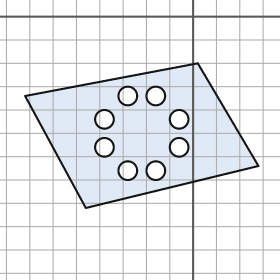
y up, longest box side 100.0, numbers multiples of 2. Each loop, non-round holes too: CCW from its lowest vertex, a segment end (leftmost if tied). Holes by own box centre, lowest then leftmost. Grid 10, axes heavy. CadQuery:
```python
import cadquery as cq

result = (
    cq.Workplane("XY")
    .moveTo(-46.0, -82.0)
    .lineTo(28.0, -64.0)
    .lineTo(2.0, -20.0)
    .lineTo(-72.0, -34.0)
    .close()
    .moveTo(-28.0, -66.0)
    .circle(4.0)
    .moveTo(-16.0, -66.0)
    .circle(4.0)
    .moveTo(-38.0, -56.0)
    .circle(4.0)
    .moveTo(-6.0, -56.0)
    .circle(4.0)
    .moveTo(-38.0, -44.0)
    .circle(4.0)
    .moveTo(-6.0, -44.0)
    .circle(4.0)
    .moveTo(-28.0, -34.0)
    .circle(4.0)
    .moveTo(-16.0, -34.0)
    .circle(4.0)
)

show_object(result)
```